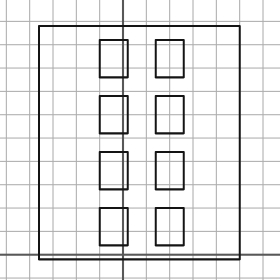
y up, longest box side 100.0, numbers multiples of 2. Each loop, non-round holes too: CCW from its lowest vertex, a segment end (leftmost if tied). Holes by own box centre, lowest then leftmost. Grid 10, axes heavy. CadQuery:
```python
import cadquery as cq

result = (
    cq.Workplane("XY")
    .moveTo(-36.0, -2.0)
    .lineTo(50.0, -2.0)
    .lineTo(50.0, 98.0)
    .lineTo(-36.0, 98.0)
    .close()
    .moveTo(-10.0, 4.0)
    .lineTo(2.0, 4.0)
    .lineTo(2.0, 20.0)
    .lineTo(-10.0, 20.0)
    .close()
    .moveTo(14.0, 4.0)
    .lineTo(26.0, 4.0)
    .lineTo(26.0, 20.0)
    .lineTo(14.0, 20.0)
    .close()
    .moveTo(-10.0, 28.0)
    .lineTo(2.0, 28.0)
    .lineTo(2.0, 44.0)
    .lineTo(-10.0, 44.0)
    .close()
    .moveTo(14.0, 28.0)
    .lineTo(26.0, 28.0)
    .lineTo(26.0, 44.0)
    .lineTo(14.0, 44.0)
    .close()
    .moveTo(-10.0, 52.0)
    .lineTo(2.0, 52.0)
    .lineTo(2.0, 68.0)
    .lineTo(-10.0, 68.0)
    .close()
    .moveTo(14.0, 52.0)
    .lineTo(26.0, 52.0)
    .lineTo(26.0, 68.0)
    .lineTo(14.0, 68.0)
    .close()
    .moveTo(-10.0, 76.0)
    .lineTo(2.0, 76.0)
    .lineTo(2.0, 92.0)
    .lineTo(-10.0, 92.0)
    .close()
    .moveTo(14.0, 76.0)
    .lineTo(26.0, 76.0)
    .lineTo(26.0, 92.0)
    .lineTo(14.0, 92.0)
    .close()
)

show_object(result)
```